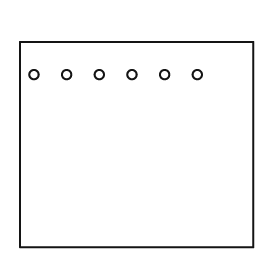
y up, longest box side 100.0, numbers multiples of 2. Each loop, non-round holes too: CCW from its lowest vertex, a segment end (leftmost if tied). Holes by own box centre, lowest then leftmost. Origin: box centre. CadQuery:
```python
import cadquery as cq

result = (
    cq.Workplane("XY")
    .moveTo(-50.0, -44.0)
    .lineTo(50.0, -44.0)
    .lineTo(50.0, 44.0)
    .lineTo(-50.0, 44.0)
    .close()
    .moveTo(-44.0, 30.0)
    .circle(2.0)
    .moveTo(-30.0, 30.0)
    .circle(2.0)
    .moveTo(-16.0, 30.0)
    .circle(2.0)
    .moveTo(-2.0, 30.0)
    .circle(2.0)
    .moveTo(12.0, 30.0)
    .circle(2.0)
    .moveTo(26.0, 30.0)
    .circle(2.0)
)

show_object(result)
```